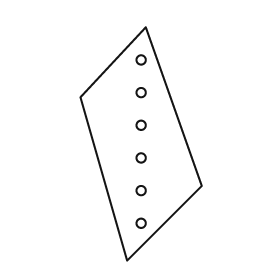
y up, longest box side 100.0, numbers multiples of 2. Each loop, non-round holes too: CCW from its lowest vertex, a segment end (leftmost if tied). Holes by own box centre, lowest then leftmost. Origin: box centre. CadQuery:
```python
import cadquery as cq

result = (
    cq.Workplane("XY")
    .moveTo(-6.0, -50.0)
    .lineTo(26.0, -18.0)
    .lineTo(2.0, 50.0)
    .lineTo(-26.0, 20.0)
    .close()
    .moveTo(0.0, -34.0)
    .circle(2.0)
    .moveTo(0.0, -20.0)
    .circle(2.0)
    .moveTo(0.0, -6.0)
    .circle(2.0)
    .moveTo(0.0, 8.0)
    .circle(2.0)
    .moveTo(0.0, 22.0)
    .circle(2.0)
    .moveTo(0.0, 36.0)
    .circle(2.0)
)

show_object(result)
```